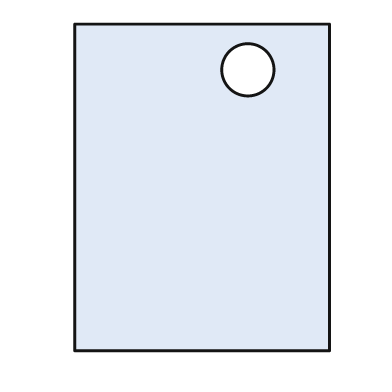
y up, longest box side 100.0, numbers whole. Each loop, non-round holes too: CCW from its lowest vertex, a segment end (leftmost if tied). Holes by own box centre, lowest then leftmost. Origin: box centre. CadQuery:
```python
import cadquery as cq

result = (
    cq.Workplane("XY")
    .moveTo(-39.0, -50.0)
    .lineTo(39.0, -50.0)
    .lineTo(39.0, 50.0)
    .lineTo(-39.0, 50.0)
    .close()
    .moveTo(14.0, 36.0)
    .circle(8.0)
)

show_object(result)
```